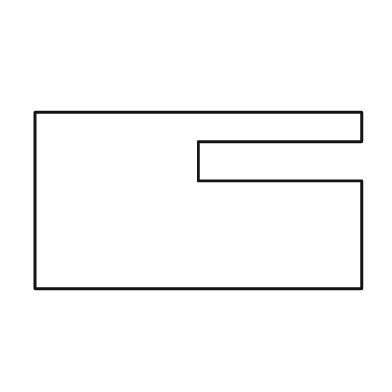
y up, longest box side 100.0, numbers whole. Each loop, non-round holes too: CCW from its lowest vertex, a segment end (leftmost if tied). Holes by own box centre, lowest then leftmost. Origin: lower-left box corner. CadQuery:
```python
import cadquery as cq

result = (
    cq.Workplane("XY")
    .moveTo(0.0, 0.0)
    .lineTo(100.0, 0.0)
    .lineTo(100.0, 33.0)
    .lineTo(50.0, 33.0)
    .lineTo(50.0, 45.0)
    .lineTo(100.0, 45.0)
    .lineTo(100.0, 54.0)
    .lineTo(0.0, 54.0)
    .close()
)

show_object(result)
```